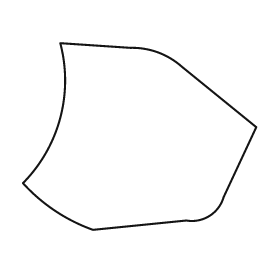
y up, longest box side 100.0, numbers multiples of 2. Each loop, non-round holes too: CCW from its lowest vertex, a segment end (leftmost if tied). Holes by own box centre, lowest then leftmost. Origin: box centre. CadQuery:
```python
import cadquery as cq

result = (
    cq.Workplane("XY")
    .moveTo(-20.0, -40.0)
    .lineTo(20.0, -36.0)
    .threePointArc((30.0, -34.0), (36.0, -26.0))
    .lineTo(50.0, 4.0)
    .lineTo(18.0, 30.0)
    .threePointArc((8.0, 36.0), (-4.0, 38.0))
    .lineTo(-34.0, 40.0)
    .threePointArc((-34.0, 8.0), (-50.0, -20.0))
    .threePointArc((-36.0, -32.0), (-20.0, -40.0))
    .close()
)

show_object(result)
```